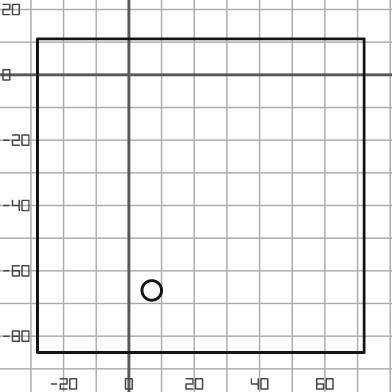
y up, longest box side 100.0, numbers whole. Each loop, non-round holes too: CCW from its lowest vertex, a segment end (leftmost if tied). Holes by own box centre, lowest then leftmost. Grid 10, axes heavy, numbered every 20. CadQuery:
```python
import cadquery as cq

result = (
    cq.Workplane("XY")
    .moveTo(-28.0, -85.0)
    .lineTo(72.0, -85.0)
    .lineTo(72.0, 11.0)
    .lineTo(-28.0, 11.0)
    .close()
    .moveTo(7.0, -66.0)
    .circle(3.0)
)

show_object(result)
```